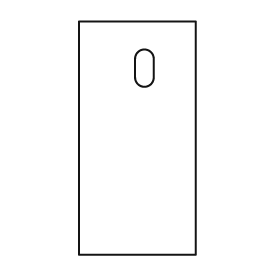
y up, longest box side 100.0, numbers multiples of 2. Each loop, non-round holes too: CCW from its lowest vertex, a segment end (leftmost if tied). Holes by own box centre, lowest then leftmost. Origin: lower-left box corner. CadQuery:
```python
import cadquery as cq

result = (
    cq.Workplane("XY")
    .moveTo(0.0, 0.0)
    .lineTo(50.0, 0.0)
    .lineTo(50.0, 100.0)
    .lineTo(0.0, 100.0)
    .close()
    .moveTo(24.0, 76.0)
    .threePointArc((28.0, 72.0), (32.0, 76.0))
    .lineTo(32.0, 84.0)
    .threePointArc((28.0, 88.0), (24.0, 84.0))
    .close()
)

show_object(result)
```